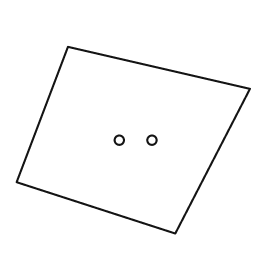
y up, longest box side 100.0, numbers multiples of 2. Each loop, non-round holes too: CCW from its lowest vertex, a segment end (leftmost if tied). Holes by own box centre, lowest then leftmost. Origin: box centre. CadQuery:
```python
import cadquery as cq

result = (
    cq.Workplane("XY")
    .moveTo(18.0, -40.0)
    .lineTo(50.0, 22.0)
    .lineTo(-28.0, 40.0)
    .lineTo(-50.0, -18.0)
    .close()
    .moveTo(-6.0, 0.0)
    .circle(2.0)
    .moveTo(8.0, 0.0)
    .circle(2.0)
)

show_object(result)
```